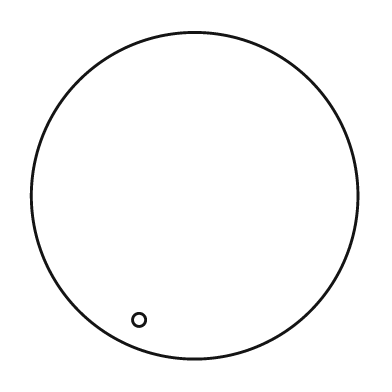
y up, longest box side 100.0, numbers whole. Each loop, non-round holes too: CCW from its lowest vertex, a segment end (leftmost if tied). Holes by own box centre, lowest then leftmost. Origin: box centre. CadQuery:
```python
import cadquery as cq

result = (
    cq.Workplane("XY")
    .moveTo(0.0, 0.0)
    .circle(50.0)
    .moveTo(-17.0, -38.0)
    .circle(2.0)
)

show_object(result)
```